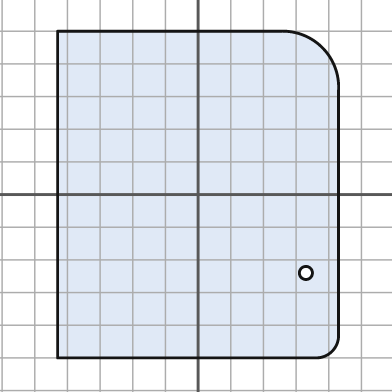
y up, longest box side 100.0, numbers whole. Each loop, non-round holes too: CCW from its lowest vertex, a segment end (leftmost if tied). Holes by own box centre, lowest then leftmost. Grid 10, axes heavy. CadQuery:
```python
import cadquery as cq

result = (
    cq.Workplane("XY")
    .moveTo(-43.0, -50.0)
    .lineTo(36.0, -50.0)
    .threePointArc((41.0, -48.0), (43.0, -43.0))
    .lineTo(43.0, 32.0)
    .threePointArc((38.0, 45.0), (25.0, 50.0))
    .lineTo(-43.0, 50.0)
    .close()
    .moveTo(33.0, -24.0)
    .circle(2.0)
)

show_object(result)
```